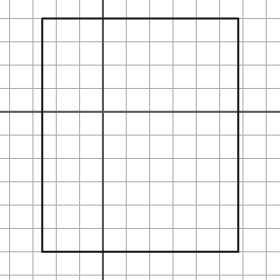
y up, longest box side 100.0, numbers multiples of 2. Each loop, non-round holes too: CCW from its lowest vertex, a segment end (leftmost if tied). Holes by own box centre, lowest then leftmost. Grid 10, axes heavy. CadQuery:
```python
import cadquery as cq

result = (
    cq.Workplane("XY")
    .moveTo(-26.0, -60.0)
    .lineTo(58.0, -60.0)
    .lineTo(58.0, 40.0)
    .lineTo(-26.0, 40.0)
    .close()
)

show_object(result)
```